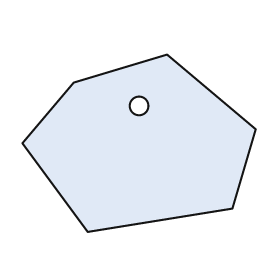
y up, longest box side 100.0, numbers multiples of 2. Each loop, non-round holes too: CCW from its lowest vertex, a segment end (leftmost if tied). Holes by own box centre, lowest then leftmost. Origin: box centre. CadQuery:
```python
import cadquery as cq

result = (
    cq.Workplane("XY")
    .moveTo(-22.0, -38.0)
    .lineTo(40.0, -28.0)
    .lineTo(50.0, 6.0)
    .lineTo(12.0, 38.0)
    .lineTo(-28.0, 26.0)
    .lineTo(-50.0, 0.0)
    .close()
    .moveTo(0.0, 16.0)
    .circle(4.0)
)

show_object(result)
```